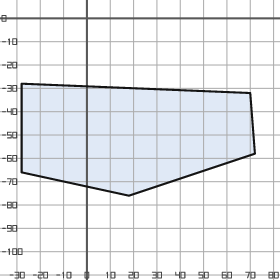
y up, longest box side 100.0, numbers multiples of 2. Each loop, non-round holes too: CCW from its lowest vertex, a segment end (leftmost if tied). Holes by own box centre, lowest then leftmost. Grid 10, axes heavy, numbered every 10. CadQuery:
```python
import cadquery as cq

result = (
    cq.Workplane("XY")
    .moveTo(18.0, -76.0)
    .lineTo(72.0, -58.0)
    .lineTo(70.0, -32.0)
    .lineTo(-28.0, -28.0)
    .lineTo(-28.0, -66.0)
    .close()
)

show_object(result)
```